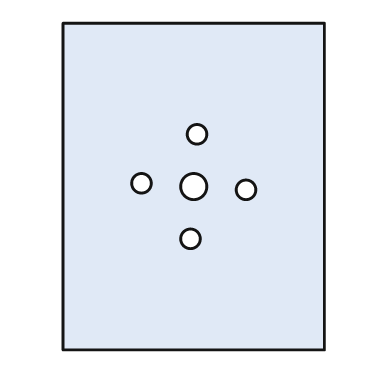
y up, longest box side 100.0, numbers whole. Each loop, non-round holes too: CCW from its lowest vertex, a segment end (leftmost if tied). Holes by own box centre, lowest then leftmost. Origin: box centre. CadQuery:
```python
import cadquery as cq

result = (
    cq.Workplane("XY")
    .moveTo(-40.0, -50.0)
    .lineTo(40.0, -50.0)
    .lineTo(40.0, 50.0)
    .lineTo(-40.0, 50.0)
    .close()
    .moveTo(-1.0, -16.0)
    .circle(3.0)
    .moveTo(16.0, -1.0)
    .circle(3.0)
    .moveTo(0.0, 0.0)
    .circle(4.0)
    .moveTo(-16.0, 1.0)
    .circle(3.0)
    .moveTo(1.0, 16.0)
    .circle(3.0)
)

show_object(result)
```